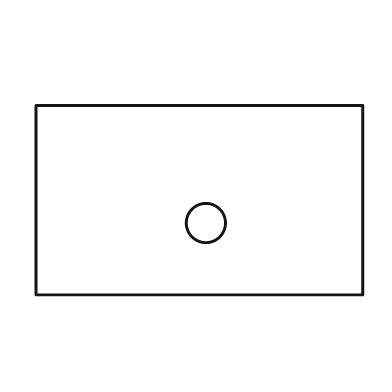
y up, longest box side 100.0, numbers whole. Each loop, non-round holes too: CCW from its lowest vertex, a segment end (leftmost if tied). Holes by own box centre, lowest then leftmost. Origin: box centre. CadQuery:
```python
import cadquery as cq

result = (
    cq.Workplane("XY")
    .moveTo(-50.0, -29.0)
    .lineTo(50.0, -29.0)
    .lineTo(50.0, 29.0)
    .lineTo(-50.0, 29.0)
    .close()
    .moveTo(2.0, -7.0)
    .circle(6.0)
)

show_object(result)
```